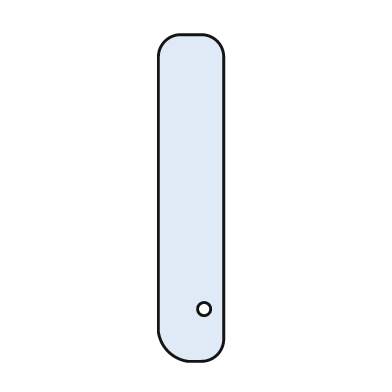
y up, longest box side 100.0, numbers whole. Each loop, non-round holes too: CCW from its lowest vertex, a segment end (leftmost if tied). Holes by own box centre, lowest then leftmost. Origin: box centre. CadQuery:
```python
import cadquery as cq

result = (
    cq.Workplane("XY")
    .moveTo(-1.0, -50.0)
    .lineTo(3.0, -50.0)
    .threePointArc((8.0, -48.0), (10.0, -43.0))
    .lineTo(10.0, 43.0)
    .threePointArc((8.0, 48.0), (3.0, 50.0))
    .lineTo(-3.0, 50.0)
    .threePointArc((-8.0, 48.0), (-10.0, 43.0))
    .lineTo(-10.0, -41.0)
    .threePointArc((-7.0, -47.0), (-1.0, -50.0))
    .close()
    .moveTo(4.0, -34.0)
    .circle(2.0)
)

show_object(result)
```